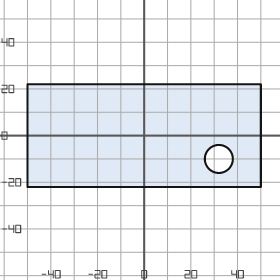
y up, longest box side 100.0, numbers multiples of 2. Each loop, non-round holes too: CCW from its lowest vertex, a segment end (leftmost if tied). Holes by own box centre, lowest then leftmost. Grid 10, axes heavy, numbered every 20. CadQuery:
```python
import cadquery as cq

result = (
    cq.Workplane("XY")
    .moveTo(-50.0, -22.0)
    .lineTo(50.0, -22.0)
    .lineTo(50.0, 22.0)
    .lineTo(-50.0, 22.0)
    .close()
    .moveTo(32.0, -10.0)
    .circle(6.0)
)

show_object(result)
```